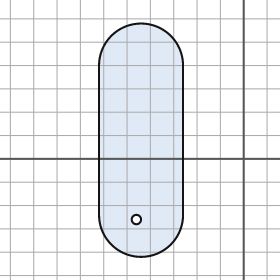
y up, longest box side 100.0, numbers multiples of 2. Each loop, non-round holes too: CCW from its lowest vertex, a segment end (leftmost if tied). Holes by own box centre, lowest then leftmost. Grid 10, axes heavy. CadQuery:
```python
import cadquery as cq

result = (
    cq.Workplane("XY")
    .moveTo(-62.0, -24.0)
    .threePointArc((-44.0, -42.0), (-26.0, -24.0))
    .lineTo(-26.0, 40.0)
    .threePointArc((-44.0, 58.0), (-62.0, 40.0))
    .close()
    .moveTo(-46.0, -26.0)
    .circle(2.0)
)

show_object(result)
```